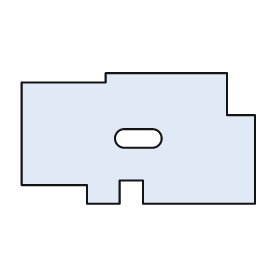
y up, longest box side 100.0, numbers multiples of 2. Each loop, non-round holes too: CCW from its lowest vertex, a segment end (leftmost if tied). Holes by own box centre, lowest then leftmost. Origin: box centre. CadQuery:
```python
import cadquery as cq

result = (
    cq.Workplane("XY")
    .moveTo(-22.0, -28.0)
    .lineTo(-8.0, -28.0)
    .lineTo(-8.0, -18.0)
    .lineTo(2.0, -18.0)
    .lineTo(2.0, -28.0)
    .lineTo(50.0, -28.0)
    .lineTo(50.0, 10.0)
    .lineTo(38.0, 10.0)
    .lineTo(38.0, 28.0)
    .lineTo(-14.0, 28.0)
    .lineTo(-14.0, 24.0)
    .lineTo(-50.0, 24.0)
    .lineTo(-50.0, -20.0)
    .lineTo(-22.0, -20.0)
    .close()
    .moveTo(-6.0, -4.0)
    .lineTo(6.0, -4.0)
    .threePointArc((10.0, 0.0), (6.0, 4.0))
    .lineTo(-6.0, 4.0)
    .threePointArc((-10.0, 0.0), (-6.0, -4.0))
    .close()
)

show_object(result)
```